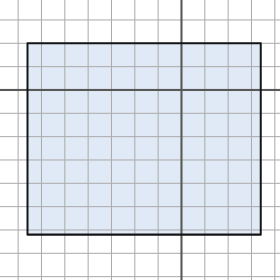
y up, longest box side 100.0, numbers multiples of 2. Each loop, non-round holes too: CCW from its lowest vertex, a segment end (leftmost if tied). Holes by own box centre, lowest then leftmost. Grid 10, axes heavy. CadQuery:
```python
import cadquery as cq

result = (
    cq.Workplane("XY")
    .moveTo(-66.0, -62.0)
    .lineTo(34.0, -62.0)
    .lineTo(34.0, 20.0)
    .lineTo(-66.0, 20.0)
    .close()
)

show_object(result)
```